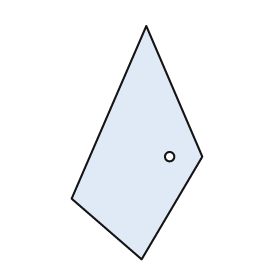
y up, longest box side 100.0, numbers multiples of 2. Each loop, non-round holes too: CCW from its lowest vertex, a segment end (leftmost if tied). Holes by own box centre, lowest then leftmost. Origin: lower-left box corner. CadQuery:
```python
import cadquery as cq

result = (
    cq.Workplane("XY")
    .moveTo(30.0, 0.0)
    .lineTo(56.0, 44.0)
    .lineTo(32.0, 100.0)
    .lineTo(0.0, 26.0)
    .close()
    .moveTo(42.0, 44.0)
    .circle(2.0)
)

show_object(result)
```